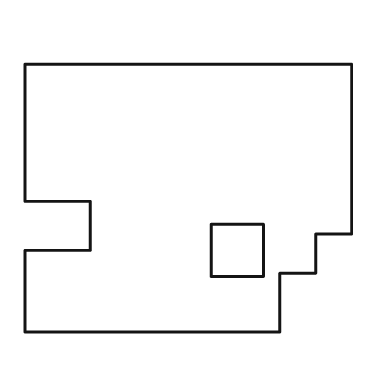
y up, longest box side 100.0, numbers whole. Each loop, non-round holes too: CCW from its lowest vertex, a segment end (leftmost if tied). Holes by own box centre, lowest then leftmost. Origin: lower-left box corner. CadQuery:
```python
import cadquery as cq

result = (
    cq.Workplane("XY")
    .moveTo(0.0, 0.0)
    .lineTo(78.0, 0.0)
    .lineTo(78.0, 18.0)
    .lineTo(89.0, 18.0)
    .lineTo(89.0, 30.0)
    .lineTo(100.0, 30.0)
    .lineTo(100.0, 82.0)
    .lineTo(0.0, 82.0)
    .lineTo(0.0, 40.0)
    .lineTo(20.0, 40.0)
    .lineTo(20.0, 25.0)
    .lineTo(0.0, 25.0)
    .close()
    .moveTo(57.0, 17.0)
    .lineTo(73.0, 17.0)
    .lineTo(73.0, 33.0)
    .lineTo(57.0, 33.0)
    .close()
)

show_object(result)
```